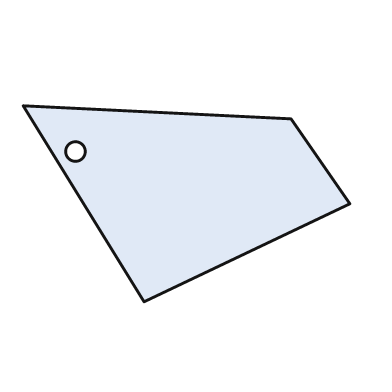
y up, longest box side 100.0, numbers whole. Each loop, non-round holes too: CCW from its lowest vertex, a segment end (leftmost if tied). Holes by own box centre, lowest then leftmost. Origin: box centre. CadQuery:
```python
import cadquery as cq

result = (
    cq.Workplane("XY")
    .moveTo(-13.0, -30.0)
    .lineTo(50.0, 0.0)
    .lineTo(32.0, 26.0)
    .lineTo(-50.0, 30.0)
    .close()
    .moveTo(-34.0, 16.0)
    .circle(3.0)
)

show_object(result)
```